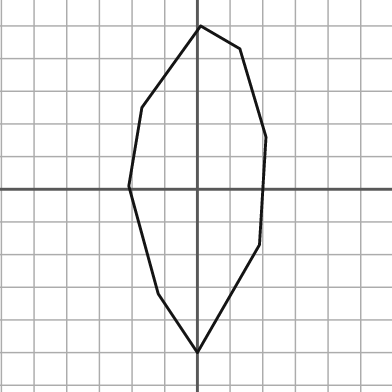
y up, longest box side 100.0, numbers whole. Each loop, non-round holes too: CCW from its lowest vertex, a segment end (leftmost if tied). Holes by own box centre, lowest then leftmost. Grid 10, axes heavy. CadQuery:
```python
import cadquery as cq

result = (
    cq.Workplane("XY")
    .moveTo(0.0, -50.0)
    .lineTo(19.0, -17.0)
    .lineTo(21.0, 16.0)
    .lineTo(13.0, 43.0)
    .lineTo(1.0, 50.0)
    .lineTo(-17.0, 25.0)
    .lineTo(-21.0, 1.0)
    .lineTo(-12.0, -32.0)
    .close()
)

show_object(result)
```